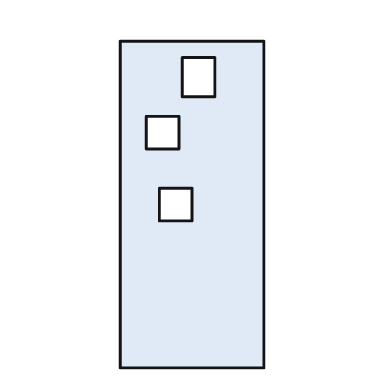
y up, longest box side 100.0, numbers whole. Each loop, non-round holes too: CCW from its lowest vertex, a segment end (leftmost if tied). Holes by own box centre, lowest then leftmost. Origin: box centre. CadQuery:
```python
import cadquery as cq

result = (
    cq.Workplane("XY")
    .moveTo(-22.0, -50.0)
    .lineTo(22.0, -50.0)
    .lineTo(22.0, 50.0)
    .lineTo(-22.0, 50.0)
    .close()
    .moveTo(-10.0, -5.0)
    .lineTo(0.0, -5.0)
    .lineTo(0.0, 5.0)
    .lineTo(-10.0, 5.0)
    .close()
    .moveTo(-14.0, 17.0)
    .lineTo(-4.0, 17.0)
    .lineTo(-4.0, 27.0)
    .lineTo(-14.0, 27.0)
    .close()
    .moveTo(-3.0, 33.0)
    .lineTo(7.0, 33.0)
    .lineTo(7.0, 45.0)
    .lineTo(-3.0, 45.0)
    .close()
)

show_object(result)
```